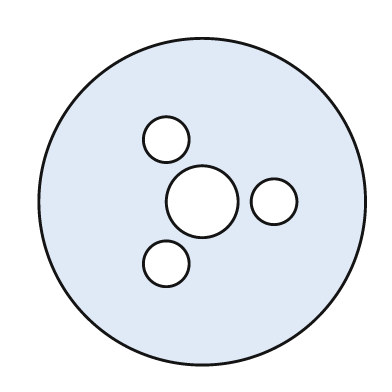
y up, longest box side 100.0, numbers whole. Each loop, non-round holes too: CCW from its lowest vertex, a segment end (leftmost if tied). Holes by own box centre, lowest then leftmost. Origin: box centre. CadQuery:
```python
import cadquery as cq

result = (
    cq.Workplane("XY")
    .moveTo(0.0, 0.0)
    .circle(50.0)
    .moveTo(-11.0, -19.0)
    .circle(7.0)
    .moveTo(0.0, 0.0)
    .circle(11.0)
    .moveTo(22.0, 0.0)
    .circle(7.0)
    .moveTo(-11.0, 19.0)
    .circle(7.0)
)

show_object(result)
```